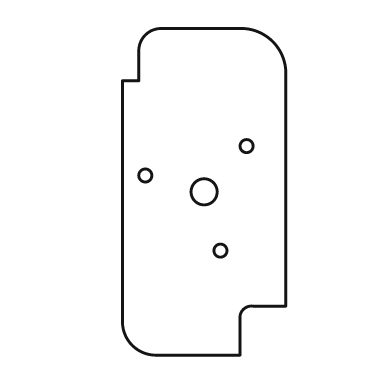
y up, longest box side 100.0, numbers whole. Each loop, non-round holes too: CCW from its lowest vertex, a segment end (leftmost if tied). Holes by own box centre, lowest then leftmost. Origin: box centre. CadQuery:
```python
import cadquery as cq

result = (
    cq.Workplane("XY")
    .moveTo(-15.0, -50.0)
    .lineTo(11.0, -50.0)
    .lineTo(11.0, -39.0)
    .threePointArc((12.0, -36.0), (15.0, -35.0))
    .lineTo(25.0, -35.0)
    .lineTo(25.0, 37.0)
    .threePointArc((21.0, 46.0), (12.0, 50.0))
    .lineTo(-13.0, 50.0)
    .threePointArc((-18.0, 48.0), (-20.0, 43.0))
    .lineTo(-20.0, 34.0)
    .lineTo(-25.0, 34.0)
    .lineTo(-25.0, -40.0)
    .threePointArc((-22.0, -47.0), (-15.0, -50.0))
    .close()
    .moveTo(5.0, -18.0)
    .circle(2.0)
    .moveTo(0.0, 0.0)
    .circle(4.0)
    .moveTo(-18.0, 5.0)
    .circle(2.0)
    .moveTo(13.0, 14.0)
    .circle(2.0)
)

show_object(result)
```